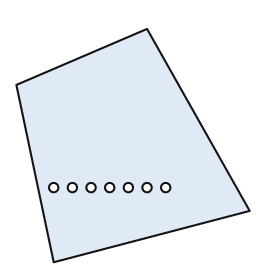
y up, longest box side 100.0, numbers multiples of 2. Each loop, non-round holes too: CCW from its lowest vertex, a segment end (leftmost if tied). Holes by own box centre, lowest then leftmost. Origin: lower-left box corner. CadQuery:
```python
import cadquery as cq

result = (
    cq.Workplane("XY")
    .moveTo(16.0, 0.0)
    .lineTo(100.0, 22.0)
    .lineTo(56.0, 100.0)
    .lineTo(0.0, 76.0)
    .close()
    .moveTo(16.0, 32.0)
    .circle(2.0)
    .moveTo(24.0, 32.0)
    .circle(2.0)
    .moveTo(32.0, 32.0)
    .circle(2.0)
    .moveTo(40.0, 32.0)
    .circle(2.0)
    .moveTo(48.0, 32.0)
    .circle(2.0)
    .moveTo(56.0, 32.0)
    .circle(2.0)
    .moveTo(64.0, 32.0)
    .circle(2.0)
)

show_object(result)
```